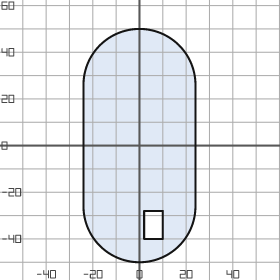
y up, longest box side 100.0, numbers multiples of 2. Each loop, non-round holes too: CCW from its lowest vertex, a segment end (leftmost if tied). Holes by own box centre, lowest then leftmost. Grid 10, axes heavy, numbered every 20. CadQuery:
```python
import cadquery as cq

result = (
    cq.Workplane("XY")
    .moveTo(-24.0, -26.0)
    .threePointArc((0.0, -50.0), (24.0, -26.0))
    .lineTo(24.0, 26.0)
    .threePointArc((0.0, 50.0), (-24.0, 26.0))
    .close()
    .moveTo(2.0, -40.0)
    .lineTo(10.0, -40.0)
    .lineTo(10.0, -28.0)
    .lineTo(2.0, -28.0)
    .close()
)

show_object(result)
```